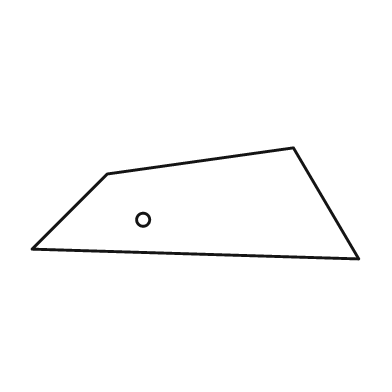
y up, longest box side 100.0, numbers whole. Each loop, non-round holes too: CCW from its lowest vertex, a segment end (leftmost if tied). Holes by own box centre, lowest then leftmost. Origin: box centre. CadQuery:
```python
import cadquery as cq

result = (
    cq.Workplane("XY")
    .moveTo(50.0, -17.0)
    .lineTo(30.0, 17.0)
    .lineTo(-27.0, 9.0)
    .lineTo(-50.0, -14.0)
    .close()
    .moveTo(-16.0, -5.0)
    .circle(2.0)
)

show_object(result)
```